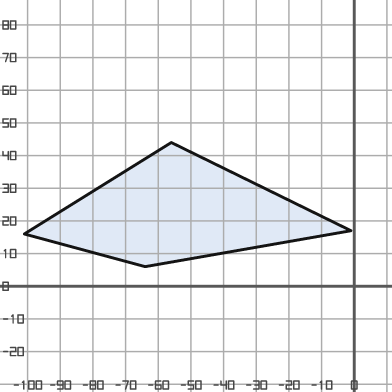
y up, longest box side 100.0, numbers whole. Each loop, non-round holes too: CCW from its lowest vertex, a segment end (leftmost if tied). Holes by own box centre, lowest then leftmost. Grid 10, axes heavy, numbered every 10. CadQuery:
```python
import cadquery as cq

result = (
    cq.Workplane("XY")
    .moveTo(-64.0, 6.0)
    .lineTo(-1.0, 17.0)
    .lineTo(-56.0, 44.0)
    .lineTo(-101.0, 16.0)
    .close()
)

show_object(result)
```